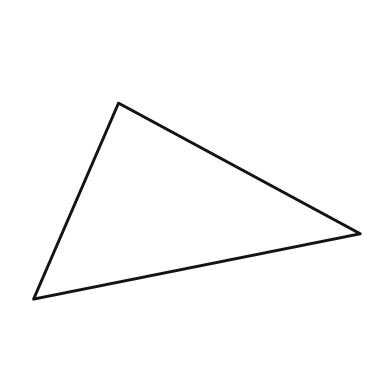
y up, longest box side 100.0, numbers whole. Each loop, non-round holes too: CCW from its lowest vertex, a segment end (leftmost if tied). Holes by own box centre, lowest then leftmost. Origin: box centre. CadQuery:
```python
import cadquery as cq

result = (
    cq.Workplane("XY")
    .moveTo(-50.0, -30.0)
    .lineTo(50.0, -10.0)
    .lineTo(-24.0, 30.0)
    .close()
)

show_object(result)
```